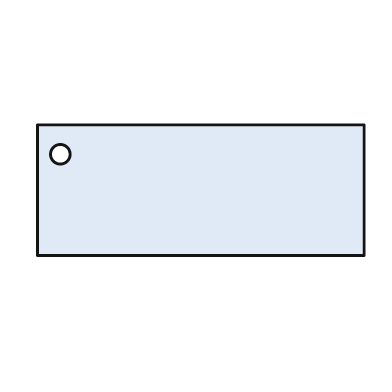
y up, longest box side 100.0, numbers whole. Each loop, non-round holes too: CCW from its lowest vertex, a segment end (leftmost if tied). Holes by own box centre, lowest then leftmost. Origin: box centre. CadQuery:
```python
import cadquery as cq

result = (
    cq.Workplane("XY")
    .moveTo(-50.0, -20.0)
    .lineTo(50.0, -20.0)
    .lineTo(50.0, 20.0)
    .lineTo(-50.0, 20.0)
    .close()
    .moveTo(-43.0, 11.0)
    .circle(3.0)
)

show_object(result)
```